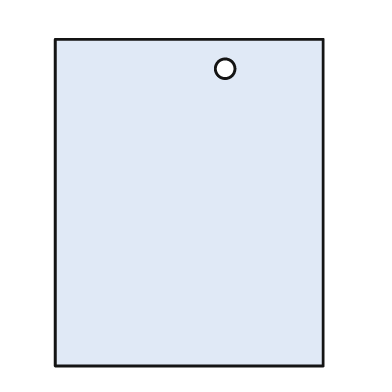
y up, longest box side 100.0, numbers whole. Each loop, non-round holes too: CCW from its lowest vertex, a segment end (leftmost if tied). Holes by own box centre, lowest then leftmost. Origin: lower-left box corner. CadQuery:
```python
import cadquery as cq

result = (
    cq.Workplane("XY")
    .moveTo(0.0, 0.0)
    .lineTo(82.0, 0.0)
    .lineTo(82.0, 100.0)
    .lineTo(0.0, 100.0)
    .close()
    .moveTo(52.0, 91.0)
    .circle(3.0)
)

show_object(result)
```